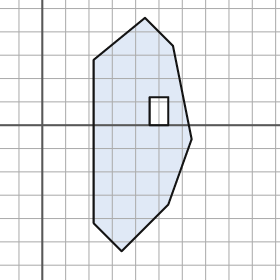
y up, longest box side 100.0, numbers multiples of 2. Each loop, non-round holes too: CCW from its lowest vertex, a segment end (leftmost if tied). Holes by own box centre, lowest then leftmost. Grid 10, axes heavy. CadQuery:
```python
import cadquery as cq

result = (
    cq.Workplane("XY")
    .moveTo(34.0, -54.0)
    .lineTo(54.0, -34.0)
    .lineTo(64.0, -6.0)
    .lineTo(56.0, 34.0)
    .lineTo(44.0, 46.0)
    .lineTo(22.0, 28.0)
    .lineTo(22.0, -42.0)
    .close()
    .moveTo(46.0, 0.0)
    .lineTo(54.0, 0.0)
    .lineTo(54.0, 12.0)
    .lineTo(46.0, 12.0)
    .close()
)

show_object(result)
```